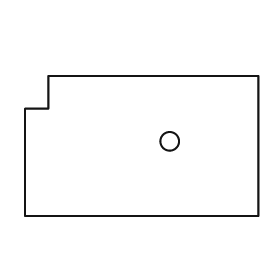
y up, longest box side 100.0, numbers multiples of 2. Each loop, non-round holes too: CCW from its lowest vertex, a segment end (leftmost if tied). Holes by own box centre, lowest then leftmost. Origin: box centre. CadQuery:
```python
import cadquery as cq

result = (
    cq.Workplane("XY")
    .moveTo(-50.0, -30.0)
    .lineTo(50.0, -30.0)
    .lineTo(50.0, 30.0)
    .lineTo(-40.0, 30.0)
    .lineTo(-40.0, 16.0)
    .lineTo(-50.0, 16.0)
    .close()
    .moveTo(12.0, 2.0)
    .circle(4.0)
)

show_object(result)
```